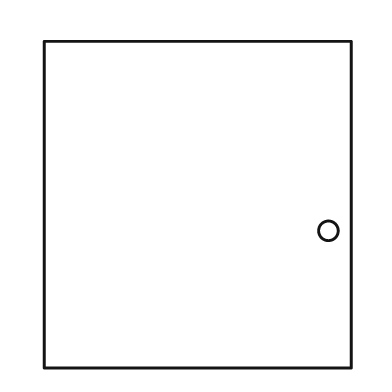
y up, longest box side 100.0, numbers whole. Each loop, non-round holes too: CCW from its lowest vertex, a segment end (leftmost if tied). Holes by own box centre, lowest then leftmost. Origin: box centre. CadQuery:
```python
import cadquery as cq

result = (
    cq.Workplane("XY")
    .moveTo(-47.0, -50.0)
    .lineTo(47.0, -50.0)
    .lineTo(47.0, 50.0)
    .lineTo(-47.0, 50.0)
    .close()
    .moveTo(40.0, -8.0)
    .circle(3.0)
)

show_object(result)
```